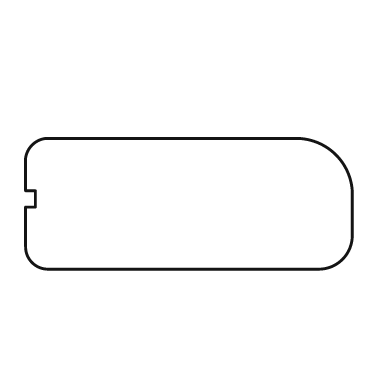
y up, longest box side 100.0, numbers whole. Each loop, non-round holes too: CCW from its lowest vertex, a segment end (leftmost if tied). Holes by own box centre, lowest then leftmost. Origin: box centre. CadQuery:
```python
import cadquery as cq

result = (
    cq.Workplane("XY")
    .moveTo(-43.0, -20.0)
    .lineTo(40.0, -20.0)
    .threePointArc((47.0, -17.0), (50.0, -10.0))
    .lineTo(50.0, 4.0)
    .threePointArc((45.0, 15.0), (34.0, 20.0))
    .lineTo(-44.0, 20.0)
    .threePointArc((-48.0, 18.0), (-50.0, 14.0))
    .lineTo(-50.0, 4.0)
    .lineTo(-47.0, 4.0)
    .lineTo(-47.0, -1.0)
    .lineTo(-50.0, -1.0)
    .lineTo(-50.0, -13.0)
    .threePointArc((-48.0, -18.0), (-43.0, -20.0))
    .close()
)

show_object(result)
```